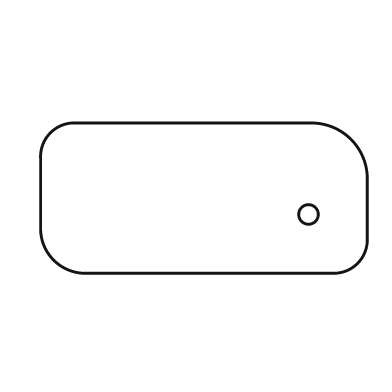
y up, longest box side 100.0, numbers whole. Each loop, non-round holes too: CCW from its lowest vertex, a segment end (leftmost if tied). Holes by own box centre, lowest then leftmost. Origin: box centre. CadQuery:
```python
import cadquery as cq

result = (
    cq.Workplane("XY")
    .moveTo(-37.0, -23.0)
    .lineTo(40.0, -23.0)
    .threePointArc((47.0, -20.0), (50.0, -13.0))
    .lineTo(50.0, 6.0)
    .threePointArc((45.0, 18.0), (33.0, 23.0))
    .lineTo(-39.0, 23.0)
    .threePointArc((-47.0, 20.0), (-50.0, 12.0))
    .lineTo(-50.0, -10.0)
    .threePointArc((-46.0, -19.0), (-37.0, -23.0))
    .close()
    .moveTo(32.0, -5.0)
    .circle(3.0)
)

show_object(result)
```